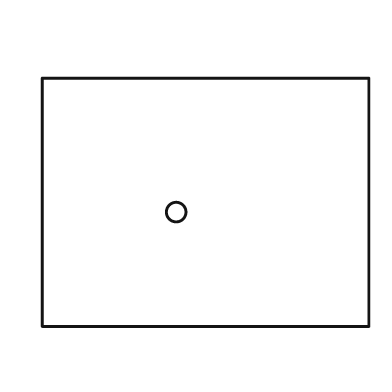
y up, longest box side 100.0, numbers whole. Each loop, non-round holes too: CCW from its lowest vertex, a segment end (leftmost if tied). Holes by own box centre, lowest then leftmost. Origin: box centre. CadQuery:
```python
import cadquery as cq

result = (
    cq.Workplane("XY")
    .moveTo(-50.0, -38.0)
    .lineTo(50.0, -38.0)
    .lineTo(50.0, 38.0)
    .lineTo(-50.0, 38.0)
    .close()
    .moveTo(-9.0, -3.0)
    .circle(3.0)
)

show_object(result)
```